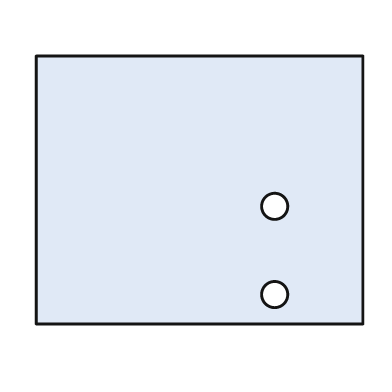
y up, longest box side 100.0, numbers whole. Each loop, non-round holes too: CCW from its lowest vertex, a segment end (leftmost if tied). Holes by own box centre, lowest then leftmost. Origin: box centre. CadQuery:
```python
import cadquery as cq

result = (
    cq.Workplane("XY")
    .moveTo(-50.0, -41.0)
    .lineTo(50.0, -41.0)
    .lineTo(50.0, 41.0)
    .lineTo(-50.0, 41.0)
    .close()
    .moveTo(23.0, -32.0)
    .circle(4.0)
    .moveTo(23.0, -5.0)
    .circle(4.0)
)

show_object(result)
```